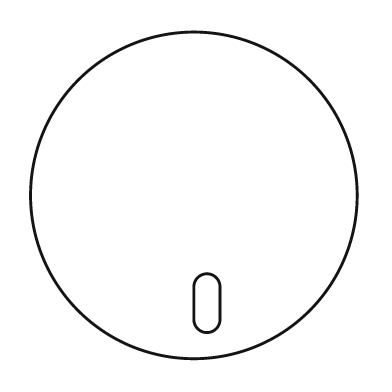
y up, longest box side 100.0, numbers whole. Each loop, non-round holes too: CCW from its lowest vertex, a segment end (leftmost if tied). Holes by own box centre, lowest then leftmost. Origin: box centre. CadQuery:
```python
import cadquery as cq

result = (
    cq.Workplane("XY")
    .moveTo(0.0, 0.0)
    .circle(50.0)
    .moveTo(0.0, -38.0)
    .threePointArc((4.0, -42.0), (8.0, -38.0))
    .lineTo(8.0, -28.0)
    .threePointArc((4.0, -24.0), (0.0, -28.0))
    .close()
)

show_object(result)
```